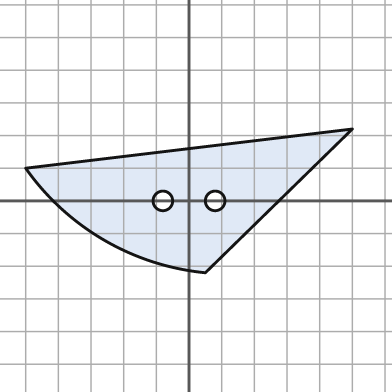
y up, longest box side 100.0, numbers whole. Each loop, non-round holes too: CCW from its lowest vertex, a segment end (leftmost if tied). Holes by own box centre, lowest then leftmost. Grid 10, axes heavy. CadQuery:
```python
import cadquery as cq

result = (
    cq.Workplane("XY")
    .moveTo(5.0, -22.0)
    .lineTo(50.0, 22.0)
    .lineTo(-50.0, 10.0)
    .threePointArc((-26.0, -12.0), (5.0, -22.0))
    .close()
    .moveTo(-8.0, 0.0)
    .circle(3.0)
    .moveTo(8.0, 0.0)
    .circle(3.0)
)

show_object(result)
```